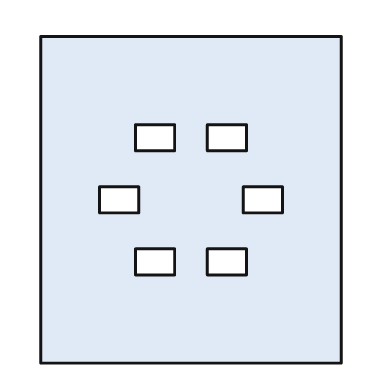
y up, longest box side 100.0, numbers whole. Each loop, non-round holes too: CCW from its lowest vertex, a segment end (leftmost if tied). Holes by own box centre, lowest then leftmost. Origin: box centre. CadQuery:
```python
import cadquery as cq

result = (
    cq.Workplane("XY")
    .moveTo(-46.0, -50.0)
    .lineTo(46.0, -50.0)
    .lineTo(46.0, 50.0)
    .lineTo(-46.0, 50.0)
    .close()
    .moveTo(-17.0, -23.0)
    .lineTo(-5.0, -23.0)
    .lineTo(-5.0, -15.0)
    .lineTo(-17.0, -15.0)
    .close()
    .moveTo(5.0, -23.0)
    .lineTo(17.0, -23.0)
    .lineTo(17.0, -15.0)
    .lineTo(5.0, -15.0)
    .close()
    .moveTo(-28.0, -4.0)
    .lineTo(-16.0, -4.0)
    .lineTo(-16.0, 4.0)
    .lineTo(-28.0, 4.0)
    .close()
    .moveTo(16.0, -4.0)
    .lineTo(28.0, -4.0)
    .lineTo(28.0, 4.0)
    .lineTo(16.0, 4.0)
    .close()
    .moveTo(-17.0, 15.0)
    .lineTo(-5.0, 15.0)
    .lineTo(-5.0, 23.0)
    .lineTo(-17.0, 23.0)
    .close()
    .moveTo(5.0, 15.0)
    .lineTo(17.0, 15.0)
    .lineTo(17.0, 23.0)
    .lineTo(5.0, 23.0)
    .close()
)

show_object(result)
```